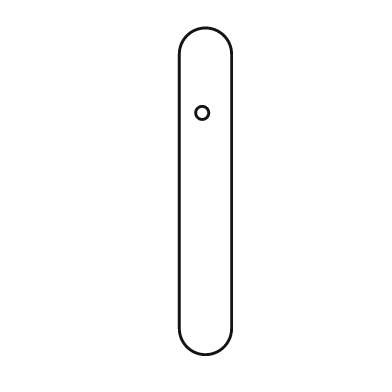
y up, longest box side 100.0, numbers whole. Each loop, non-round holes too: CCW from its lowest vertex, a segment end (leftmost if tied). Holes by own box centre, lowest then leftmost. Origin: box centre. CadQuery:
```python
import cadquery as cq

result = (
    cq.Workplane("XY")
    .moveTo(-8.0, -42.0)
    .threePointArc((0.0, -50.0), (8.0, -42.0))
    .lineTo(8.0, 42.0)
    .threePointArc((0.0, 50.0), (-8.0, 42.0))
    .close()
    .moveTo(-1.0, 24.0)
    .circle(2.0)
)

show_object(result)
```